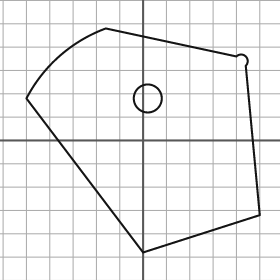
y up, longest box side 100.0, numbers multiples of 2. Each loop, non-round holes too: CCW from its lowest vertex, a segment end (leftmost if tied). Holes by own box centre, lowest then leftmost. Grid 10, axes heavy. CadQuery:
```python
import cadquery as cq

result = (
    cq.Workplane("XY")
    .moveTo(0.0, -48.0)
    .lineTo(50.0, -32.0)
    .lineTo(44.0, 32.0)
    .threePointArc((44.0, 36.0), (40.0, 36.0))
    .lineTo(-16.0, 48.0)
    .threePointArc((-36.0, 36.0), (-50.0, 18.0))
    .close()
    .moveTo(2.0, 18.0)
    .circle(6.0)
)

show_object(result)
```